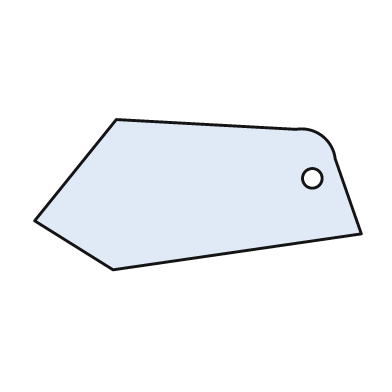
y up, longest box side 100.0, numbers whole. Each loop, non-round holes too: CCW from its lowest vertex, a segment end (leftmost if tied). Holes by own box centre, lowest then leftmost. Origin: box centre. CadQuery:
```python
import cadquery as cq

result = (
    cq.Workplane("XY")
    .moveTo(-26.0, -23.0)
    .lineTo(50.0, -12.0)
    .lineTo(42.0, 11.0)
    .threePointArc((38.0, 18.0), (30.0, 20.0))
    .lineTo(-25.0, 23.0)
    .lineTo(-50.0, -8.0)
    .close()
    .moveTo(35.0, 5.0)
    .circle(3.0)
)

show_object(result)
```